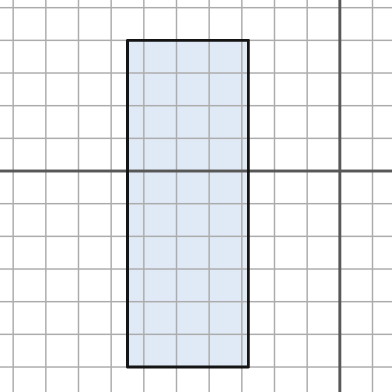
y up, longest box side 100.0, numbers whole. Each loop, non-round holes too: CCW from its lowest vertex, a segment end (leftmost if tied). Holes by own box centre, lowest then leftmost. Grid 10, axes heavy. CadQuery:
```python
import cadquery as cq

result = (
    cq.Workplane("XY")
    .moveTo(-65.0, -60.0)
    .lineTo(-28.0, -60.0)
    .lineTo(-28.0, 40.0)
    .lineTo(-65.0, 40.0)
    .close()
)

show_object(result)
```